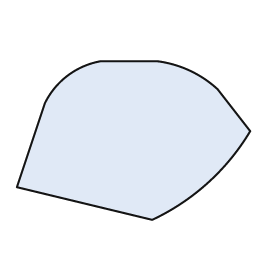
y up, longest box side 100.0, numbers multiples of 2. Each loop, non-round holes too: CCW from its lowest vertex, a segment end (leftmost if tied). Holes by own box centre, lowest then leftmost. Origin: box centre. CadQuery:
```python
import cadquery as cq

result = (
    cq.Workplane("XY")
    .moveTo(8.0, -34.0)
    .threePointArc((32.0, -18.0), (50.0, 4.0))
    .lineTo(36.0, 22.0)
    .threePointArc((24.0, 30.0), (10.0, 34.0))
    .lineTo(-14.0, 34.0)
    .threePointArc((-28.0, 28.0), (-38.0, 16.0))
    .lineTo(-50.0, -20.0)
    .close()
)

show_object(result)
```